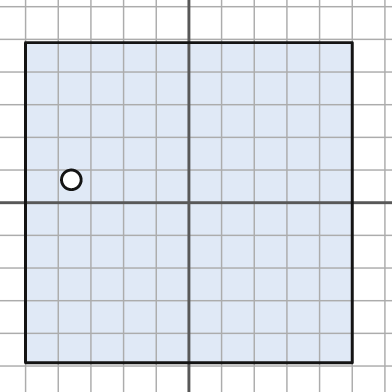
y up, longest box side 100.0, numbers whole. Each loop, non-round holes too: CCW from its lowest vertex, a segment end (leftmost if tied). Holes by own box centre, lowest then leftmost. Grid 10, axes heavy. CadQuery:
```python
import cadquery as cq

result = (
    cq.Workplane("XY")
    .moveTo(-50.0, -49.0)
    .lineTo(50.0, -49.0)
    .lineTo(50.0, 49.0)
    .lineTo(-50.0, 49.0)
    .close()
    .moveTo(-36.0, 7.0)
    .circle(3.0)
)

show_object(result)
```